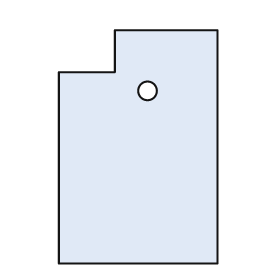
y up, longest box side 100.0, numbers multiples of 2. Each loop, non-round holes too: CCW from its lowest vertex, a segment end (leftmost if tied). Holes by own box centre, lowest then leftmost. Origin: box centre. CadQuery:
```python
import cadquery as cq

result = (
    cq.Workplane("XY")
    .moveTo(-34.0, -50.0)
    .lineTo(34.0, -50.0)
    .lineTo(34.0, 50.0)
    .lineTo(-10.0, 50.0)
    .lineTo(-10.0, 32.0)
    .lineTo(-34.0, 32.0)
    .close()
    .moveTo(4.0, 24.0)
    .circle(4.0)
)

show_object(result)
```